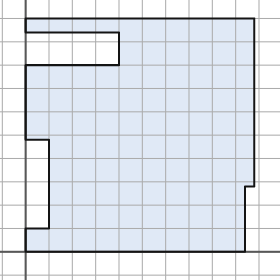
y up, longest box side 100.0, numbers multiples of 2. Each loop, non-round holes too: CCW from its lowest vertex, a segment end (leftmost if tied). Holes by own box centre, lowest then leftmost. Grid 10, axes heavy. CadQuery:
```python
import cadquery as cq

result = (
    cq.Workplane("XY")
    .moveTo(0.0, 0.0)
    .lineTo(94.0, 0.0)
    .lineTo(94.0, 28.0)
    .lineTo(98.0, 28.0)
    .lineTo(98.0, 100.0)
    .lineTo(0.0, 100.0)
    .lineTo(0.0, 94.0)
    .lineTo(40.0, 94.0)
    .lineTo(40.0, 80.0)
    .lineTo(0.0, 80.0)
    .lineTo(0.0, 48.0)
    .lineTo(10.0, 48.0)
    .lineTo(10.0, 10.0)
    .lineTo(0.0, 10.0)
    .close()
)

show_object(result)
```